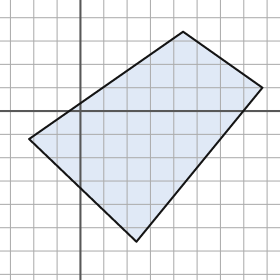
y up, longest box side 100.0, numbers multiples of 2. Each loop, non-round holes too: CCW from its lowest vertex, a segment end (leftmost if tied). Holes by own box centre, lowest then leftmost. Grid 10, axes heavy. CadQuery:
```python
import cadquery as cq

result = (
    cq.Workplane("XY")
    .moveTo(24.0, -56.0)
    .lineTo(78.0, 10.0)
    .lineTo(44.0, 34.0)
    .lineTo(-22.0, -12.0)
    .close()
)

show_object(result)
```